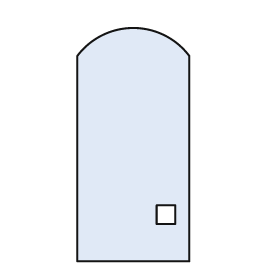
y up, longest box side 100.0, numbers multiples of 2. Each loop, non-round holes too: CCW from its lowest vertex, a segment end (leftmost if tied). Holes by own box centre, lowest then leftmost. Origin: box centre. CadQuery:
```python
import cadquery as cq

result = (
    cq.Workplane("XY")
    .moveTo(-24.0, -50.0)
    .lineTo(24.0, -50.0)
    .lineTo(24.0, 38.0)
    .threePointArc((0.0, 50.0), (-24.0, 38.0))
    .close()
    .moveTo(10.0, -34.0)
    .lineTo(18.0, -34.0)
    .lineTo(18.0, -26.0)
    .lineTo(10.0, -26.0)
    .close()
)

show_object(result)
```